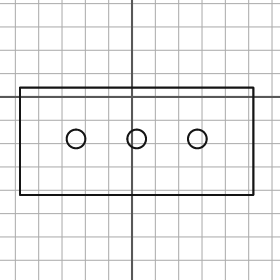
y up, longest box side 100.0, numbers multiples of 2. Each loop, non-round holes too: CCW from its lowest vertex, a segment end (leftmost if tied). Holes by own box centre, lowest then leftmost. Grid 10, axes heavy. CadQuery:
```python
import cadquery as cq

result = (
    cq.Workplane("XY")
    .moveTo(-48.0, -42.0)
    .lineTo(52.0, -42.0)
    .lineTo(52.0, 4.0)
    .lineTo(-48.0, 4.0)
    .close()
    .moveTo(-24.0, -18.0)
    .circle(4.0)
    .moveTo(2.0, -18.0)
    .circle(4.0)
    .moveTo(28.0, -18.0)
    .circle(4.0)
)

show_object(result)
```